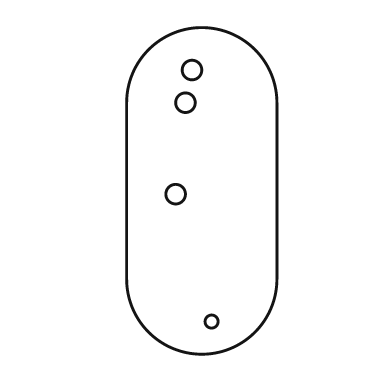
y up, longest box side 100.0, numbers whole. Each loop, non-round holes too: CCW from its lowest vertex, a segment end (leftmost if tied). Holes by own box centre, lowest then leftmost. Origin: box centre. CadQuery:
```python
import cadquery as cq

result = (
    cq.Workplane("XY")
    .moveTo(-23.0, -27.0)
    .threePointArc((0.0, -50.0), (23.0, -27.0))
    .lineTo(23.0, 27.0)
    .threePointArc((0.0, 50.0), (-23.0, 27.0))
    .close()
    .moveTo(3.0, -40.0)
    .circle(2.0)
    .moveTo(-8.0, -1.0)
    .circle(3.0)
    .moveTo(-5.0, 27.0)
    .circle(3.0)
    .moveTo(-3.0, 37.0)
    .circle(3.0)
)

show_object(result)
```